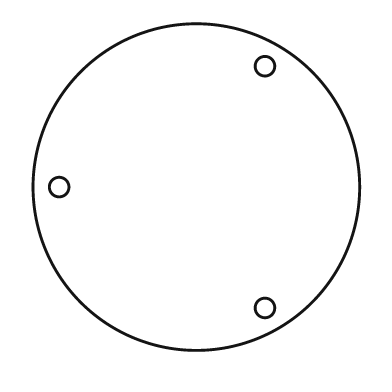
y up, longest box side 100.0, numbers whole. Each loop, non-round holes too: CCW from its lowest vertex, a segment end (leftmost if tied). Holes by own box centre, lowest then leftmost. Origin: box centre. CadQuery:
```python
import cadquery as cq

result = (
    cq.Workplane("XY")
    .moveTo(0.0, 0.0)
    .circle(50.0)
    .moveTo(21.0, -37.0)
    .circle(3.0)
    .moveTo(-42.0, 0.0)
    .circle(3.0)
    .moveTo(21.0, 37.0)
    .circle(3.0)
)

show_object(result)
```